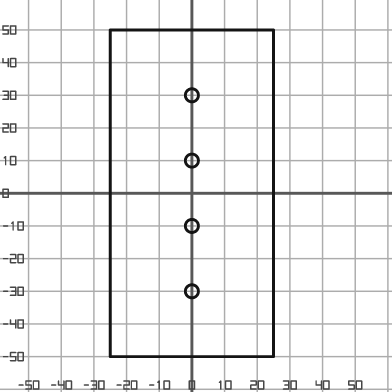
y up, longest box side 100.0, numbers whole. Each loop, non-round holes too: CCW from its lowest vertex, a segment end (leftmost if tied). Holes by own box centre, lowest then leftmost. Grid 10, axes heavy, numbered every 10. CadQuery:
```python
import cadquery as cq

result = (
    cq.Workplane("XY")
    .moveTo(-25.0, -50.0)
    .lineTo(25.0, -50.0)
    .lineTo(25.0, 50.0)
    .lineTo(-25.0, 50.0)
    .close()
    .moveTo(0.0, -30.0)
    .circle(2.0)
    .moveTo(0.0, -10.0)
    .circle(2.0)
    .moveTo(0.0, 10.0)
    .circle(2.0)
    .moveTo(0.0, 30.0)
    .circle(2.0)
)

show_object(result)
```